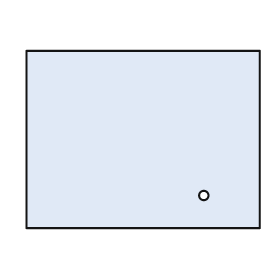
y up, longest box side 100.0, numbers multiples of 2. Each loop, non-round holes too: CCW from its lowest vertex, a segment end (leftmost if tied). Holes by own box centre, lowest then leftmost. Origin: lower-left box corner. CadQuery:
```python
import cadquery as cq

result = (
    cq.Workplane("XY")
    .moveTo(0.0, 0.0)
    .lineTo(100.0, 0.0)
    .lineTo(100.0, 76.0)
    .lineTo(0.0, 76.0)
    .close()
    .moveTo(76.0, 14.0)
    .circle(2.0)
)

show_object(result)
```